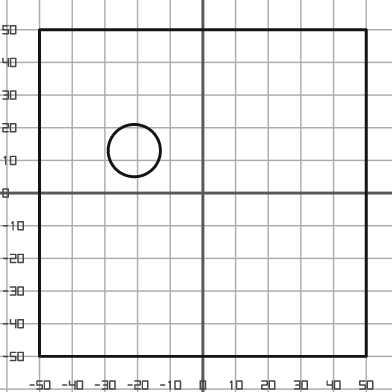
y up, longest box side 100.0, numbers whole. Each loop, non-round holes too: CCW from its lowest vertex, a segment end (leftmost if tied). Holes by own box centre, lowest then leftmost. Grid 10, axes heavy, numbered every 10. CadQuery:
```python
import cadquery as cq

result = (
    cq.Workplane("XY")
    .moveTo(-50.0, -50.0)
    .lineTo(50.0, -50.0)
    .lineTo(50.0, 50.0)
    .lineTo(-50.0, 50.0)
    .close()
    .moveTo(-21.0, 13.0)
    .circle(8.0)
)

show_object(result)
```